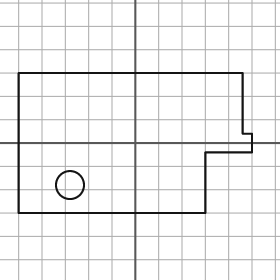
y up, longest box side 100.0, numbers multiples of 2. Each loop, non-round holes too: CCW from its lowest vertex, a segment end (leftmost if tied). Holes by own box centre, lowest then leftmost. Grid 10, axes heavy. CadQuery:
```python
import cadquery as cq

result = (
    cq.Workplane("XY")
    .moveTo(-50.0, -30.0)
    .lineTo(30.0, -30.0)
    .lineTo(30.0, -4.0)
    .lineTo(50.0, -4.0)
    .lineTo(50.0, 4.0)
    .lineTo(46.0, 4.0)
    .lineTo(46.0, 30.0)
    .lineTo(-50.0, 30.0)
    .close()
    .moveTo(-28.0, -18.0)
    .circle(6.0)
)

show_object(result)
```